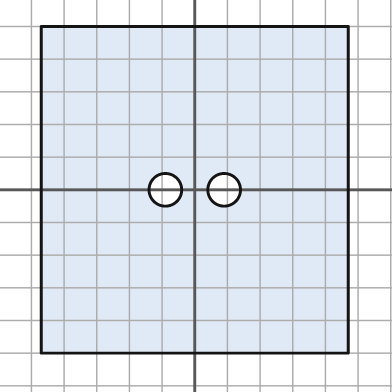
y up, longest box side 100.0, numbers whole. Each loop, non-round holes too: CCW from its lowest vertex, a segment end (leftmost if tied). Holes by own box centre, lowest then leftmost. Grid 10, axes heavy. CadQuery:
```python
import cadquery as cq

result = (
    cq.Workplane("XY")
    .moveTo(-47.0, -50.0)
    .lineTo(47.0, -50.0)
    .lineTo(47.0, 50.0)
    .lineTo(-47.0, 50.0)
    .close()
    .moveTo(-9.0, 0.0)
    .circle(5.0)
    .moveTo(9.0, 0.0)
    .circle(5.0)
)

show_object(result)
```